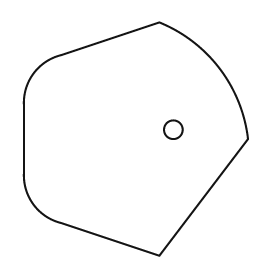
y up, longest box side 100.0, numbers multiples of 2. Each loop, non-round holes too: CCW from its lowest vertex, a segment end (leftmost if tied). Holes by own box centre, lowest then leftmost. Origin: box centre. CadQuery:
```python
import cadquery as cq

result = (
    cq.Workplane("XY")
    .moveTo(10.0, -50.0)
    .lineTo(48.0, 0.0)
    .threePointArc((36.0, 30.0), (10.0, 50.0))
    .lineTo(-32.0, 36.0)
    .threePointArc((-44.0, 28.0), (-48.0, 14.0))
    .lineTo(-48.0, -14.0)
    .threePointArc((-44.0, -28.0), (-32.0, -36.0))
    .close()
    .moveTo(16.0, 4.0)
    .circle(4.0)
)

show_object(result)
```